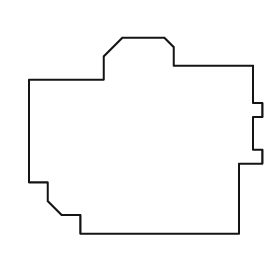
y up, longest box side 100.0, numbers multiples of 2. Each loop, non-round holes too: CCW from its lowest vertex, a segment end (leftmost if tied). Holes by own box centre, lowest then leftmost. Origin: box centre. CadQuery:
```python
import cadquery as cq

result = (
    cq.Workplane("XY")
    .moveTo(-28.0, -42.0)
    .lineTo(40.0, -42.0)
    .lineTo(40.0, -12.0)
    .lineTo(50.0, -12.0)
    .lineTo(50.0, -6.0)
    .lineTo(46.0, -6.0)
    .lineTo(46.0, 8.0)
    .lineTo(50.0, 8.0)
    .lineTo(50.0, 14.0)
    .lineTo(46.0, 14.0)
    .lineTo(46.0, 30.0)
    .lineTo(12.0, 30.0)
    .lineTo(12.0, 38.0)
    .lineTo(8.0, 42.0)
    .lineTo(-10.0, 42.0)
    .lineTo(-18.0, 34.0)
    .lineTo(-18.0, 24.0)
    .lineTo(-50.0, 24.0)
    .lineTo(-50.0, -20.0)
    .lineTo(-42.0, -20.0)
    .lineTo(-42.0, -28.0)
    .lineTo(-36.0, -34.0)
    .lineTo(-28.0, -34.0)
    .close()
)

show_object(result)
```